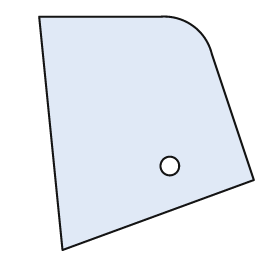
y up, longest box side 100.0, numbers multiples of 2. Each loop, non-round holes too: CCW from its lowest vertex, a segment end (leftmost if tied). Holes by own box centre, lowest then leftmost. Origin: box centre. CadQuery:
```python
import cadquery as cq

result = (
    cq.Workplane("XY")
    .moveTo(-36.0, -50.0)
    .lineTo(46.0, -20.0)
    .lineTo(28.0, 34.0)
    .threePointArc((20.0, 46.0), (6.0, 50.0))
    .lineTo(-46.0, 50.0)
    .close()
    .moveTo(10.0, -14.0)
    .circle(4.0)
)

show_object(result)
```